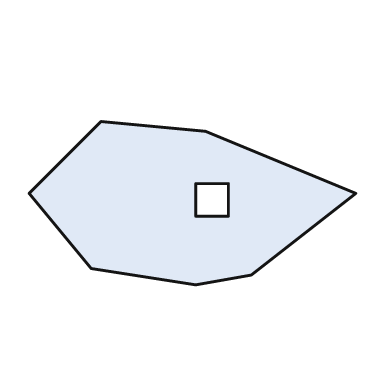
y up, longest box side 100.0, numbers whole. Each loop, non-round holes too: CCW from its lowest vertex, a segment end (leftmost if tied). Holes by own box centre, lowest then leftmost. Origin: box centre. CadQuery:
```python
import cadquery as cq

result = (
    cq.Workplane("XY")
    .moveTo(1.0, -25.0)
    .lineTo(18.0, -22.0)
    .lineTo(50.0, 3.0)
    .lineTo(4.0, 22.0)
    .lineTo(-28.0, 25.0)
    .lineTo(-50.0, 3.0)
    .lineTo(-31.0, -20.0)
    .close()
    .moveTo(1.0, -4.0)
    .lineTo(11.0, -4.0)
    .lineTo(11.0, 6.0)
    .lineTo(1.0, 6.0)
    .close()
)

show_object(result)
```